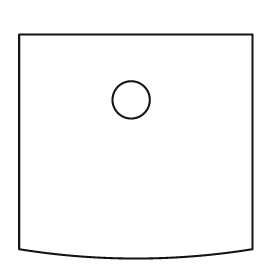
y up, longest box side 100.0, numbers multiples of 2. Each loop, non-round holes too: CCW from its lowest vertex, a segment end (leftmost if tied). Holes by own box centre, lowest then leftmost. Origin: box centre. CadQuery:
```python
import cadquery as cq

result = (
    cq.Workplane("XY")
    .moveTo(-50.0, -44.0)
    .threePointArc((0.0, -48.0), (50.0, -44.0))
    .lineTo(50.0, 48.0)
    .lineTo(-50.0, 48.0)
    .close()
    .moveTo(-2.0, 20.0)
    .circle(8.0)
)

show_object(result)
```